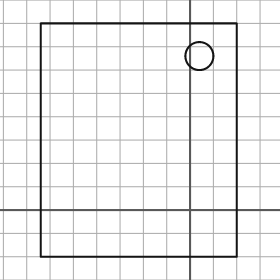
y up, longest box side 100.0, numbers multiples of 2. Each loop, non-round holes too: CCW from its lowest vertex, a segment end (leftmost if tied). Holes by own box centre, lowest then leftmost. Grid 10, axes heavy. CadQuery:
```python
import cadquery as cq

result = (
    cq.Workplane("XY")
    .moveTo(-64.0, -20.0)
    .lineTo(20.0, -20.0)
    .lineTo(20.0, 80.0)
    .lineTo(-64.0, 80.0)
    .close()
    .moveTo(4.0, 66.0)
    .circle(6.0)
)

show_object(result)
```